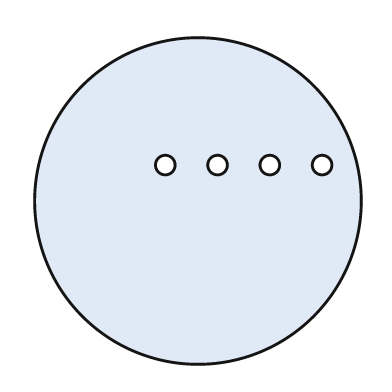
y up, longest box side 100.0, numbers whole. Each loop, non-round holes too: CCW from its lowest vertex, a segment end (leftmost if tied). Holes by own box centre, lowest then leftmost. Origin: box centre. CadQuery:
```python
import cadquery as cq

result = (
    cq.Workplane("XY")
    .moveTo(0.0, 0.0)
    .circle(50.0)
    .moveTo(-10.0, 11.0)
    .circle(3.0)
    .moveTo(6.0, 11.0)
    .circle(3.0)
    .moveTo(22.0, 11.0)
    .circle(3.0)
    .moveTo(38.0, 11.0)
    .circle(3.0)
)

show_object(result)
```